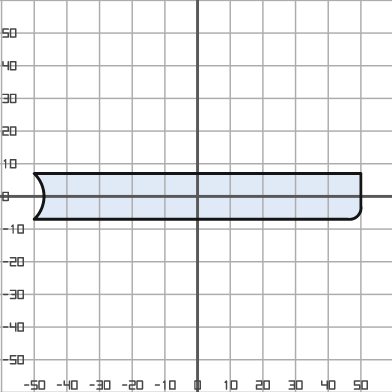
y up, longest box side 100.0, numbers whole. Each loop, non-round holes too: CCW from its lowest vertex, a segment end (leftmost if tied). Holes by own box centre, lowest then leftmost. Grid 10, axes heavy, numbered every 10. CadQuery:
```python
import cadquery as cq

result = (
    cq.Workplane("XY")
    .moveTo(-50.0, -7.0)
    .lineTo(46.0, -7.0)
    .threePointArc((49.0, -6.0), (50.0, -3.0))
    .lineTo(50.0, 7.0)
    .lineTo(-50.0, 7.0)
    .threePointArc((-47.0, 0.0), (-50.0, -7.0))
    .close()
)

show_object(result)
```